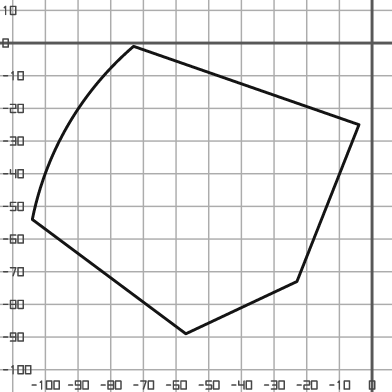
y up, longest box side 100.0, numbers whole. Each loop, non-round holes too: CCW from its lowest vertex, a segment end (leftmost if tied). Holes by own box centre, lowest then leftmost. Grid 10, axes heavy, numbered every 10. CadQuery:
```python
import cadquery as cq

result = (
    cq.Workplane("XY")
    .moveTo(-57.0, -89.0)
    .lineTo(-23.0, -73.0)
    .lineTo(-4.0, -25.0)
    .lineTo(-73.0, -1.0)
    .threePointArc((-93.0, -25.0), (-104.0, -54.0))
    .close()
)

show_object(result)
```